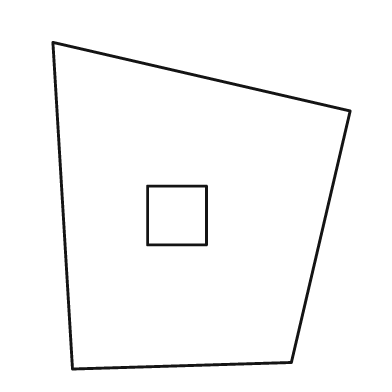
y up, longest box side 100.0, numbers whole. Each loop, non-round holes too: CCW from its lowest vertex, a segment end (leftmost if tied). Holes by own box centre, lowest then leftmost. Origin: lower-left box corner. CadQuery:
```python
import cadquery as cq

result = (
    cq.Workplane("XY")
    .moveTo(6.0, 0.0)
    .lineTo(73.0, 2.0)
    .lineTo(91.0, 79.0)
    .lineTo(0.0, 100.0)
    .close()
    .moveTo(29.0, 38.0)
    .lineTo(47.0, 38.0)
    .lineTo(47.0, 56.0)
    .lineTo(29.0, 56.0)
    .close()
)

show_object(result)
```